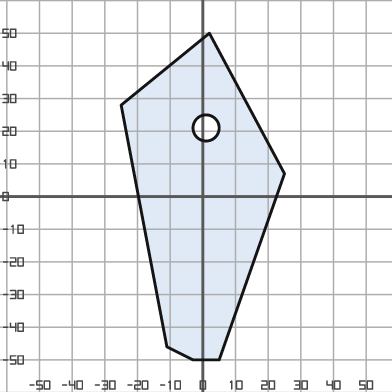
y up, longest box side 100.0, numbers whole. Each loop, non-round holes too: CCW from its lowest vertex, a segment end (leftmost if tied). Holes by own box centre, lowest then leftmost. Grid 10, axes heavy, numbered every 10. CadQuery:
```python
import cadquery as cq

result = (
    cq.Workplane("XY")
    .moveTo(-3.0, -50.0)
    .lineTo(5.0, -50.0)
    .lineTo(25.0, 7.0)
    .lineTo(2.0, 50.0)
    .lineTo(-25.0, 28.0)
    .lineTo(-11.0, -46.0)
    .close()
    .moveTo(1.0, 21.0)
    .circle(4.0)
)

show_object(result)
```